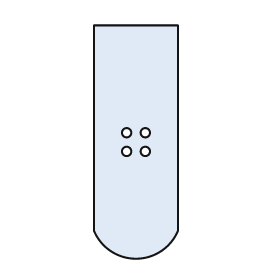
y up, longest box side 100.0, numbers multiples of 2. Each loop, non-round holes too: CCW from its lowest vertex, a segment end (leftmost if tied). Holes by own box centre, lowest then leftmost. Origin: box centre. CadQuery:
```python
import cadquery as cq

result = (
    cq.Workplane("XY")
    .moveTo(-18.0, -38.0)
    .threePointArc((0.0, -50.0), (18.0, -38.0))
    .lineTo(18.0, 50.0)
    .lineTo(-18.0, 50.0)
    .close()
    .moveTo(-4.0, -4.0)
    .circle(2.0)
    .moveTo(4.0, -4.0)
    .circle(2.0)
    .moveTo(-4.0, 4.0)
    .circle(2.0)
    .moveTo(4.0, 4.0)
    .circle(2.0)
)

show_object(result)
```